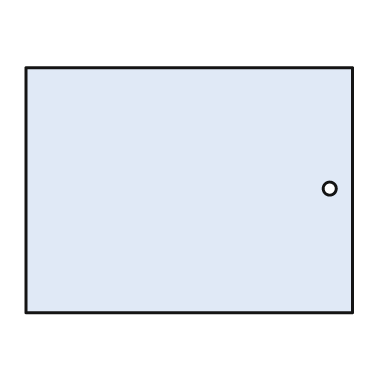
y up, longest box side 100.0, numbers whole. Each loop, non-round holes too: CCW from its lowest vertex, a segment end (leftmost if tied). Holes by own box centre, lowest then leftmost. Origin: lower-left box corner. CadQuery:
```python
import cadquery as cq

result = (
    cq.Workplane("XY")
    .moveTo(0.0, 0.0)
    .lineTo(100.0, 0.0)
    .lineTo(100.0, 75.0)
    .lineTo(0.0, 75.0)
    .close()
    .moveTo(93.0, 38.0)
    .circle(2.0)
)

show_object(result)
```